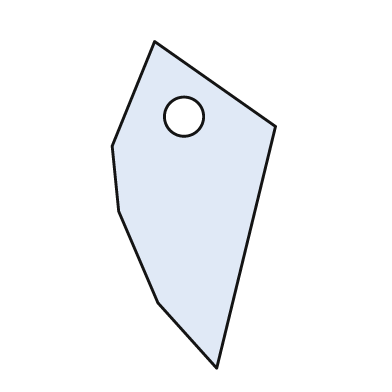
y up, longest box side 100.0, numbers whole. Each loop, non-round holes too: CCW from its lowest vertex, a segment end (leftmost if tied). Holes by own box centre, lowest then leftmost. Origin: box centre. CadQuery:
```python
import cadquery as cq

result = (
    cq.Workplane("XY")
    .moveTo(7.0, -50.0)
    .lineTo(25.0, 24.0)
    .lineTo(-12.0, 50.0)
    .lineTo(-25.0, 18.0)
    .lineTo(-23.0, -2.0)
    .lineTo(-11.0, -30.0)
    .close()
    .moveTo(-3.0, 27.0)
    .circle(6.0)
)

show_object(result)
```